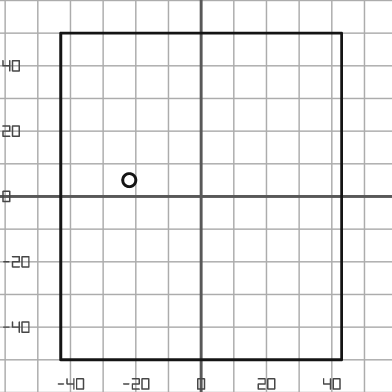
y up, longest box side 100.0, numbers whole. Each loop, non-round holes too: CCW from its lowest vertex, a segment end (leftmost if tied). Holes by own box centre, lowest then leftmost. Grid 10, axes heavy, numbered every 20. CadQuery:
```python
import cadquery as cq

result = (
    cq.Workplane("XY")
    .moveTo(-43.0, -50.0)
    .lineTo(43.0, -50.0)
    .lineTo(43.0, 50.0)
    .lineTo(-43.0, 50.0)
    .close()
    .moveTo(-22.0, 5.0)
    .circle(2.0)
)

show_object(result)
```